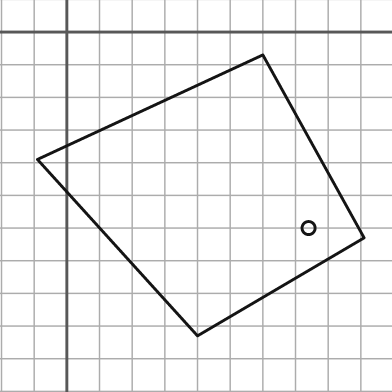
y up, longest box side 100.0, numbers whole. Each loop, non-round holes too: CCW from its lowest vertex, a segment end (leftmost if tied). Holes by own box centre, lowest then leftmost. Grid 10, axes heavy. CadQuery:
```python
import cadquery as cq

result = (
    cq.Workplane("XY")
    .moveTo(40.0, -93.0)
    .lineTo(91.0, -63.0)
    .lineTo(60.0, -7.0)
    .lineTo(-9.0, -39.0)
    .close()
    .moveTo(74.0, -60.0)
    .circle(2.0)
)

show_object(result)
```